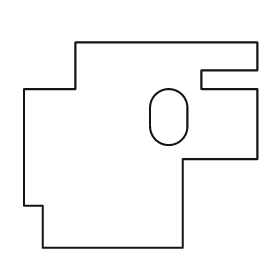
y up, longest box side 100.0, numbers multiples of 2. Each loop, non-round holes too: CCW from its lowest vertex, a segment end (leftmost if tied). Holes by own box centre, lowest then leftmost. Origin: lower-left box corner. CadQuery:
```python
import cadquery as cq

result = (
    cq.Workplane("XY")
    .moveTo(8.0, 0.0)
    .lineTo(68.0, 0.0)
    .lineTo(68.0, 38.0)
    .lineTo(100.0, 38.0)
    .lineTo(100.0, 68.0)
    .lineTo(76.0, 68.0)
    .lineTo(76.0, 76.0)
    .lineTo(100.0, 76.0)
    .lineTo(100.0, 88.0)
    .lineTo(22.0, 88.0)
    .lineTo(22.0, 68.0)
    .lineTo(0.0, 68.0)
    .lineTo(0.0, 18.0)
    .lineTo(8.0, 18.0)
    .close()
    .moveTo(54.0, 52.0)
    .threePointArc((62.0, 44.0), (70.0, 52.0))
    .lineTo(70.0, 60.0)
    .threePointArc((62.0, 68.0), (54.0, 60.0))
    .close()
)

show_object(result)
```